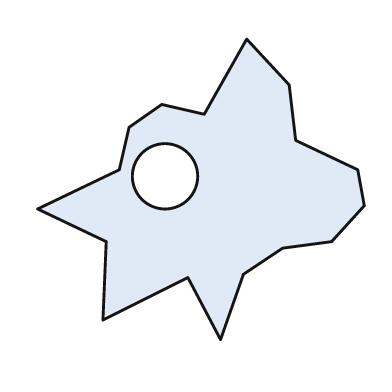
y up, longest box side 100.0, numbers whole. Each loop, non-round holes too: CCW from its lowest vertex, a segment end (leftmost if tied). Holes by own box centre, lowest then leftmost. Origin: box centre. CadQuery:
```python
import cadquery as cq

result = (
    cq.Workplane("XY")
    .moveTo(6.0, -46.0)
    .lineTo(13.0, -26.0)
    .lineTo(25.0, -18.0)
    .lineTo(40.0, -16.0)
    .lineTo(50.0, -5.0)
    .lineTo(48.0, 6.0)
    .lineTo(29.0, 15.0)
    .lineTo(27.0, 32.0)
    .lineTo(14.0, 46.0)
    .lineTo(1.0, 23.0)
    .lineTo(-12.0, 26.0)
    .lineTo(-22.0, 19.0)
    .lineTo(-25.0, 6.0)
    .lineTo(-50.0, -6.0)
    .lineTo(-29.0, -16.0)
    .lineTo(-30.0, -40.0)
    .lineTo(-4.0, -27.0)
    .close()
    .moveTo(-11.0, 4.0)
    .circle(10.0)
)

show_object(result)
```